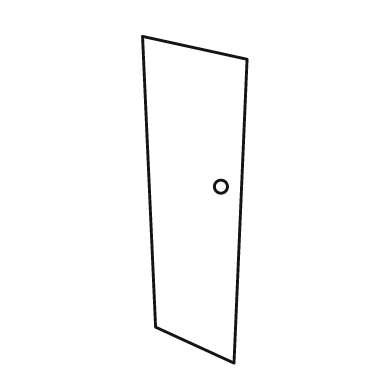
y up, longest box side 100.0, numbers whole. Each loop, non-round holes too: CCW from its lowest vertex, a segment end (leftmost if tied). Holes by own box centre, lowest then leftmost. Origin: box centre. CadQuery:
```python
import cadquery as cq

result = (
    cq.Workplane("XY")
    .moveTo(12.0, -50.0)
    .lineTo(16.0, 43.0)
    .lineTo(-16.0, 50.0)
    .lineTo(-12.0, -39.0)
    .close()
    .moveTo(8.0, 4.0)
    .circle(2.0)
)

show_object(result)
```